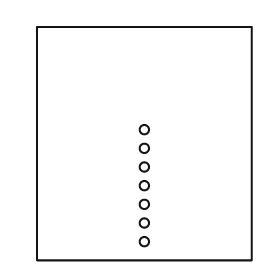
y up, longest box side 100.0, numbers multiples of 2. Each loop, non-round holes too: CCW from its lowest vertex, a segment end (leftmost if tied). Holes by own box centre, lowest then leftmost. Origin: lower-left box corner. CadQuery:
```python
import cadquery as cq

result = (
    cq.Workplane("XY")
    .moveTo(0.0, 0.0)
    .lineTo(92.0, 0.0)
    .lineTo(92.0, 100.0)
    .lineTo(0.0, 100.0)
    .close()
    .moveTo(46.0, 8.0)
    .circle(2.0)
    .moveTo(46.0, 16.0)
    .circle(2.0)
    .moveTo(46.0, 24.0)
    .circle(2.0)
    .moveTo(46.0, 32.0)
    .circle(2.0)
    .moveTo(46.0, 40.0)
    .circle(2.0)
    .moveTo(46.0, 48.0)
    .circle(2.0)
    .moveTo(46.0, 56.0)
    .circle(2.0)
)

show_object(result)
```